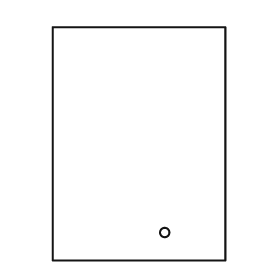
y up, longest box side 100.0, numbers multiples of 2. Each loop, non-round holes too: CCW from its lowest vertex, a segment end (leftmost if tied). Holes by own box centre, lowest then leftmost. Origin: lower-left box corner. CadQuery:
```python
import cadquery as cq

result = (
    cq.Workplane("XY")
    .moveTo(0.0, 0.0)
    .lineTo(74.0, 0.0)
    .lineTo(74.0, 100.0)
    .lineTo(0.0, 100.0)
    .close()
    .moveTo(48.0, 12.0)
    .circle(2.0)
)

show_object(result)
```